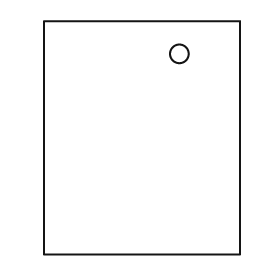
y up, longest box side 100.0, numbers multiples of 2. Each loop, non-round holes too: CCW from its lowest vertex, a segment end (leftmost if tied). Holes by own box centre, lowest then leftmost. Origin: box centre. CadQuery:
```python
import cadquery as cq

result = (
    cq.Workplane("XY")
    .moveTo(-42.0, -50.0)
    .lineTo(42.0, -50.0)
    .lineTo(42.0, 50.0)
    .lineTo(-42.0, 50.0)
    .close()
    .moveTo(16.0, 36.0)
    .circle(4.0)
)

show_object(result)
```